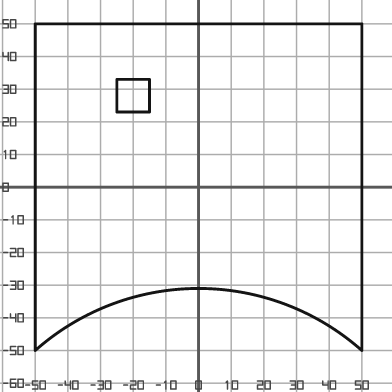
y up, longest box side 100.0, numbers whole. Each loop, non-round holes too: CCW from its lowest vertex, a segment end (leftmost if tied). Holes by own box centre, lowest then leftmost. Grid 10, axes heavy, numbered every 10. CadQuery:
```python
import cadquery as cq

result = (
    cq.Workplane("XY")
    .moveTo(-50.0, -50.0)
    .threePointArc((0.0, -31.0), (50.0, -50.0))
    .lineTo(50.0, 50.0)
    .lineTo(-50.0, 50.0)
    .close()
    .moveTo(-25.0, 23.0)
    .lineTo(-15.0, 23.0)
    .lineTo(-15.0, 33.0)
    .lineTo(-25.0, 33.0)
    .close()
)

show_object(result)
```